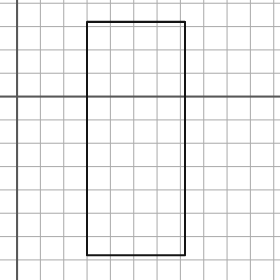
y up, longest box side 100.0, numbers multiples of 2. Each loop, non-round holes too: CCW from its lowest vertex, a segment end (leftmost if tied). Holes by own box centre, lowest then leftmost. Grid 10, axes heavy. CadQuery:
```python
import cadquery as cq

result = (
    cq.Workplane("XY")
    .moveTo(30.0, -68.0)
    .lineTo(72.0, -68.0)
    .lineTo(72.0, 32.0)
    .lineTo(30.0, 32.0)
    .close()
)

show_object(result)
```